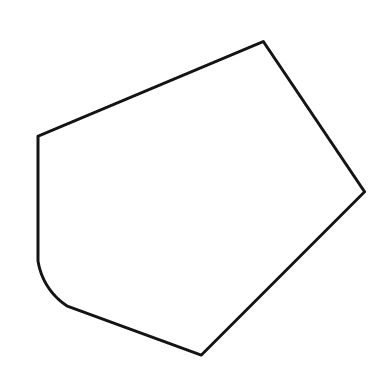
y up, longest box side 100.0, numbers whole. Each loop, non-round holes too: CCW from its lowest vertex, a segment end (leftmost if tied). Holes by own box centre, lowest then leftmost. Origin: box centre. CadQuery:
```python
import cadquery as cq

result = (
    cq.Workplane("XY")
    .moveTo(0.0, -48.0)
    .lineTo(50.0, 2.0)
    .lineTo(19.0, 48.0)
    .lineTo(-50.0, 19.0)
    .lineTo(-50.0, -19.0)
    .threePointArc((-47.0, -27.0), (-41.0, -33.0))
    .close()
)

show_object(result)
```